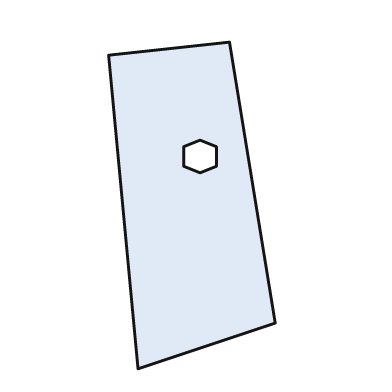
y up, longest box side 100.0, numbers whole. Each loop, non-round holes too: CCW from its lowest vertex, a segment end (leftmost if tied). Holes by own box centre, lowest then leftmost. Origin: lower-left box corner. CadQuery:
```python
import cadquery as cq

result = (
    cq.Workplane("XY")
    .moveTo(9.0, 0.0)
    .lineTo(51.0, 14.0)
    .lineTo(37.0, 100.0)
    .lineTo(0.0, 96.0)
    .close()
    .moveTo(28.0, 60.0)
    .lineTo(33.0, 62.0)
    .lineTo(33.0, 68.0)
    .lineTo(28.0, 70.0)
    .lineTo(23.0, 68.0)
    .lineTo(23.0, 62.0)
    .close()
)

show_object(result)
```